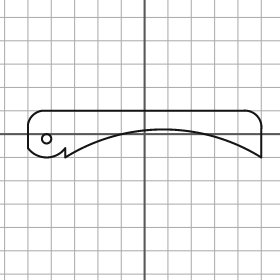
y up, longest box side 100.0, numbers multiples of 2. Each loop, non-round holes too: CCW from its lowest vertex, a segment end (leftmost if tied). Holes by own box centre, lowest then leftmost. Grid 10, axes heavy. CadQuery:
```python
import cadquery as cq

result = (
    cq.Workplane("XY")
    .moveTo(-34.0, -10.0)
    .threePointArc((8.0, 2.0), (50.0, -10.0))
    .lineTo(50.0, 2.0)
    .threePointArc((48.0, 8.0), (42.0, 10.0))
    .lineTo(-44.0, 10.0)
    .threePointArc((-48.0, 8.0), (-50.0, 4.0))
    .lineTo(-50.0, -6.0)
    .threePointArc((-42.0, -10.0), (-34.0, -6.0))
    .close()
    .moveTo(-42.0, -2.0)
    .circle(2.0)
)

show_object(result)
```